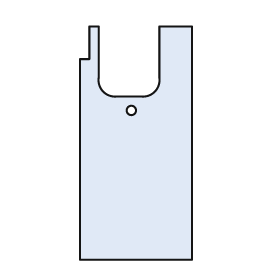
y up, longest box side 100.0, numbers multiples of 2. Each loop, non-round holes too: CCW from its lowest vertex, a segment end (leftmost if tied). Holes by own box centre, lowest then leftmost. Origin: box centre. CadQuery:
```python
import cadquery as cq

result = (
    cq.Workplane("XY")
    .moveTo(-24.0, -50.0)
    .lineTo(24.0, -50.0)
    .lineTo(24.0, 50.0)
    .lineTo(10.0, 50.0)
    .lineTo(10.0, 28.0)
    .threePointArc((8.0, 22.0), (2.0, 20.0))
    .lineTo(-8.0, 20.0)
    .threePointArc((-14.0, 22.0), (-16.0, 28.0))
    .lineTo(-16.0, 50.0)
    .lineTo(-20.0, 50.0)
    .lineTo(-20.0, 36.0)
    .lineTo(-24.0, 36.0)
    .close()
    .moveTo(-2.0, 14.0)
    .circle(2.0)
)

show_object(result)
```